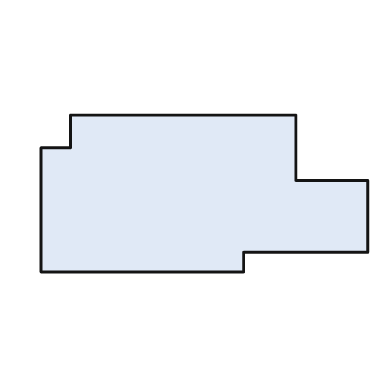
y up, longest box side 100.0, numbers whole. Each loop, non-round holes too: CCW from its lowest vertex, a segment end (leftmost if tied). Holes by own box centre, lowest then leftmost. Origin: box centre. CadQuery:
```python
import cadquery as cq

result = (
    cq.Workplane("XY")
    .moveTo(-50.0, -24.0)
    .lineTo(12.0, -24.0)
    .lineTo(12.0, -18.0)
    .lineTo(50.0, -18.0)
    .lineTo(50.0, 4.0)
    .lineTo(28.0, 4.0)
    .lineTo(28.0, 24.0)
    .lineTo(-41.0, 24.0)
    .lineTo(-41.0, 14.0)
    .lineTo(-50.0, 14.0)
    .close()
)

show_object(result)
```